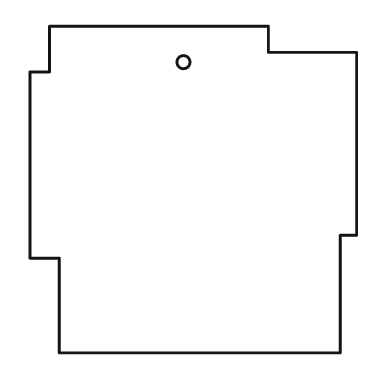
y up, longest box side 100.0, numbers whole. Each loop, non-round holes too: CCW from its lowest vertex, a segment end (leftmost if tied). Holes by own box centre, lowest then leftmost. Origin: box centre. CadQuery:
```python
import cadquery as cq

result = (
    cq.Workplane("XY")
    .moveTo(-41.0, -50.0)
    .lineTo(45.0, -50.0)
    .lineTo(45.0, -14.0)
    .lineTo(50.0, -14.0)
    .lineTo(50.0, 42.0)
    .lineTo(23.0, 42.0)
    .lineTo(23.0, 50.0)
    .lineTo(-44.0, 50.0)
    .lineTo(-44.0, 36.0)
    .lineTo(-50.0, 36.0)
    .lineTo(-50.0, -21.0)
    .lineTo(-41.0, -21.0)
    .close()
    .moveTo(-3.0, 39.0)
    .circle(2.0)
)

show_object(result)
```